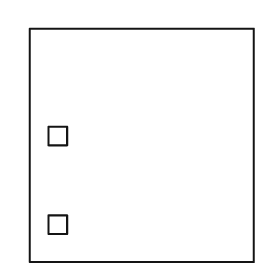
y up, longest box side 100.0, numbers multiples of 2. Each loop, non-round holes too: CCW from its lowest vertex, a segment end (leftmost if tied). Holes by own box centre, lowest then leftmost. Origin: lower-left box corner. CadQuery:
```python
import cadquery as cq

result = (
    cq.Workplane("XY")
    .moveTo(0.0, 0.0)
    .lineTo(96.0, 0.0)
    .lineTo(96.0, 100.0)
    .lineTo(0.0, 100.0)
    .close()
    .moveTo(8.0, 12.0)
    .lineTo(16.0, 12.0)
    .lineTo(16.0, 20.0)
    .lineTo(8.0, 20.0)
    .close()
    .moveTo(8.0, 50.0)
    .lineTo(16.0, 50.0)
    .lineTo(16.0, 58.0)
    .lineTo(8.0, 58.0)
    .close()
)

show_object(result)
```